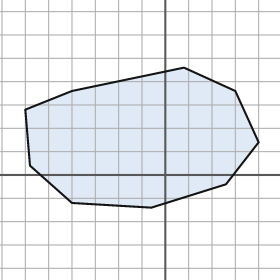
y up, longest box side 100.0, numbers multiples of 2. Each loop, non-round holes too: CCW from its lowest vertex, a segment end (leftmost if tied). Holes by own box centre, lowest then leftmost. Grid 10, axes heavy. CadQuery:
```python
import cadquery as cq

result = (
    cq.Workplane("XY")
    .moveTo(-6.0, -14.0)
    .lineTo(26.0, -4.0)
    .lineTo(40.0, 14.0)
    .lineTo(30.0, 36.0)
    .lineTo(8.0, 46.0)
    .lineTo(-40.0, 36.0)
    .lineTo(-60.0, 28.0)
    .lineTo(-58.0, 4.0)
    .lineTo(-40.0, -12.0)
    .close()
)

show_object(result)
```